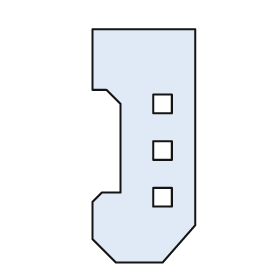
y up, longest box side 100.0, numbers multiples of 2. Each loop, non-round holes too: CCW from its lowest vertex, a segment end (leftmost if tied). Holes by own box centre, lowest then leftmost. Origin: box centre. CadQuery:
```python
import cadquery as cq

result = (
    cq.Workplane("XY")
    .moveTo(-12.0, -50.0)
    .lineTo(8.0, -50.0)
    .lineTo(22.0, -34.0)
    .lineTo(22.0, 50.0)
    .lineTo(-22.0, 50.0)
    .lineTo(-22.0, 24.0)
    .lineTo(-16.0, 24.0)
    .lineTo(-10.0, 18.0)
    .lineTo(-10.0, -20.0)
    .lineTo(-18.0, -20.0)
    .lineTo(-22.0, -24.0)
    .lineTo(-22.0, -40.0)
    .close()
    .moveTo(4.0, -26.0)
    .lineTo(12.0, -26.0)
    .lineTo(12.0, -18.0)
    .lineTo(4.0, -18.0)
    .close()
    .moveTo(4.0, -6.0)
    .lineTo(12.0, -6.0)
    .lineTo(12.0, 2.0)
    .lineTo(4.0, 2.0)
    .close()
    .moveTo(4.0, 14.0)
    .lineTo(12.0, 14.0)
    .lineTo(12.0, 22.0)
    .lineTo(4.0, 22.0)
    .close()
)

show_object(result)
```